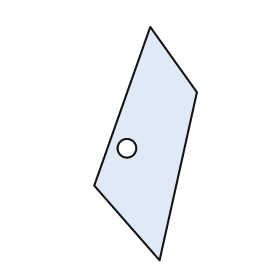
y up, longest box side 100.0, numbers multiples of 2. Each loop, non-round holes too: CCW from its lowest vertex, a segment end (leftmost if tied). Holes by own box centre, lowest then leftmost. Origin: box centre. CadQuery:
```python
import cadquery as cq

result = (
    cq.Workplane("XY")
    .moveTo(6.0, -50.0)
    .lineTo(22.0, 22.0)
    .lineTo(2.0, 50.0)
    .lineTo(-22.0, -18.0)
    .close()
    .moveTo(-8.0, -2.0)
    .circle(4.0)
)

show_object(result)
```